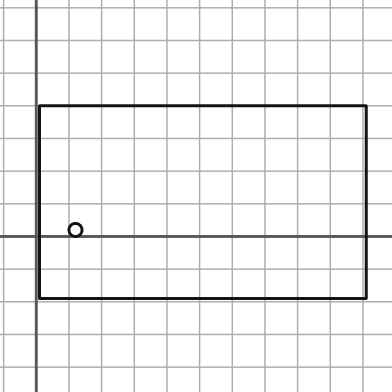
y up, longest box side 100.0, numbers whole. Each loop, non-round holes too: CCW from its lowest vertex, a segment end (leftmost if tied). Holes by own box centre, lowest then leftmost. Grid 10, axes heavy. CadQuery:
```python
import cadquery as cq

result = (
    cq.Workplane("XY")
    .moveTo(1.0, -19.0)
    .lineTo(101.0, -19.0)
    .lineTo(101.0, 40.0)
    .lineTo(1.0, 40.0)
    .close()
    .moveTo(12.0, 2.0)
    .circle(2.0)
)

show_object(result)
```